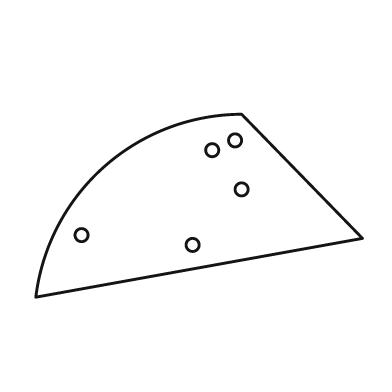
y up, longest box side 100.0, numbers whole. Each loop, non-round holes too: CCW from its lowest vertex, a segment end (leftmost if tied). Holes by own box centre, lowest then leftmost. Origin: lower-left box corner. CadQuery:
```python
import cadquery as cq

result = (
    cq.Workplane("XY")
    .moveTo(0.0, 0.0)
    .lineTo(100.0, 18.0)
    .lineTo(63.0, 56.0)
    .threePointArc((21.0, 40.0), (0.0, 0.0))
    .close()
    .moveTo(48.0, 16.0)
    .circle(2.0)
    .moveTo(14.0, 19.0)
    .circle(2.0)
    .moveTo(63.0, 33.0)
    .circle(2.0)
    .moveTo(54.0, 45.0)
    .circle(2.0)
    .moveTo(61.0, 48.0)
    .circle(2.0)
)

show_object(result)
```